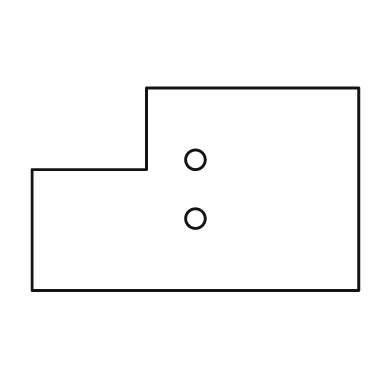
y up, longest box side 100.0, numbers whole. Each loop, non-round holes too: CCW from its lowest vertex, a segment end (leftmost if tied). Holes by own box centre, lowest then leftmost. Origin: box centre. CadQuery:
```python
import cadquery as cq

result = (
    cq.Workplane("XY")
    .moveTo(-50.0, -31.0)
    .lineTo(50.0, -31.0)
    .lineTo(50.0, 31.0)
    .lineTo(-15.0, 31.0)
    .lineTo(-15.0, 6.0)
    .lineTo(-50.0, 6.0)
    .close()
    .moveTo(0.0, -9.0)
    .circle(3.0)
    .moveTo(0.0, 9.0)
    .circle(3.0)
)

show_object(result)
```